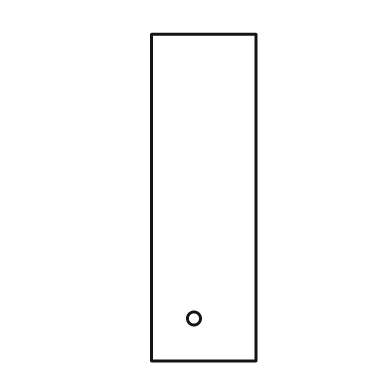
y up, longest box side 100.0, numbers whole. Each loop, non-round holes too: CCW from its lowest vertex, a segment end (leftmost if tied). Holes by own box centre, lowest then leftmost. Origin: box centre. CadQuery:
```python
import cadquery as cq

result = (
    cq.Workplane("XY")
    .moveTo(-16.0, -50.0)
    .lineTo(16.0, -50.0)
    .lineTo(16.0, 50.0)
    .lineTo(-16.0, 50.0)
    .close()
    .moveTo(-3.0, -37.0)
    .circle(2.0)
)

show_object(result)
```